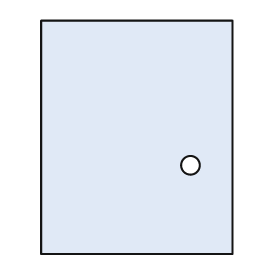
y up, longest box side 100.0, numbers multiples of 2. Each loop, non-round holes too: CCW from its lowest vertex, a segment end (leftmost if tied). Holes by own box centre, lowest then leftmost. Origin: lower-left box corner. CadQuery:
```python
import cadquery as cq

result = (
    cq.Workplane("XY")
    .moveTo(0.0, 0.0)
    .lineTo(82.0, 0.0)
    .lineTo(82.0, 100.0)
    .lineTo(0.0, 100.0)
    .close()
    .moveTo(64.0, 38.0)
    .circle(4.0)
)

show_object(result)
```